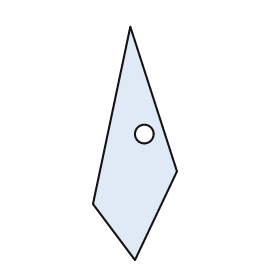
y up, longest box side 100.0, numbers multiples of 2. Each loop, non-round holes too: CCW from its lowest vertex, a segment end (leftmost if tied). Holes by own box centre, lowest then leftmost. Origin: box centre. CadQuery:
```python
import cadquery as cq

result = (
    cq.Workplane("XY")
    .moveTo(0.0, -50.0)
    .lineTo(18.0, -12.0)
    .lineTo(-2.0, 50.0)
    .lineTo(-18.0, -26.0)
    .close()
    .moveTo(4.0, 4.0)
    .circle(4.0)
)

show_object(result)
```